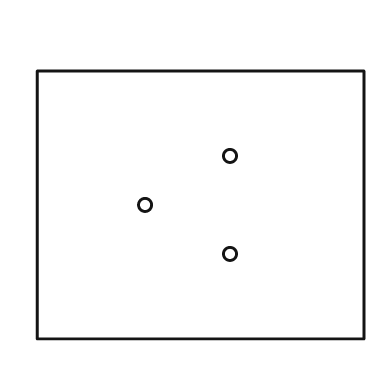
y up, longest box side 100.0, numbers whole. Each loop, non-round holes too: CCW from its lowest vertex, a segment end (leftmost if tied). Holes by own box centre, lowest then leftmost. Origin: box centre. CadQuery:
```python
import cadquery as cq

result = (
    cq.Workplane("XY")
    .moveTo(-50.0, -41.0)
    .lineTo(50.0, -41.0)
    .lineTo(50.0, 41.0)
    .lineTo(-50.0, 41.0)
    .close()
    .moveTo(9.0, -15.0)
    .circle(2.0)
    .moveTo(-17.0, 0.0)
    .circle(2.0)
    .moveTo(9.0, 15.0)
    .circle(2.0)
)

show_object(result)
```